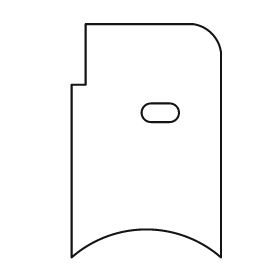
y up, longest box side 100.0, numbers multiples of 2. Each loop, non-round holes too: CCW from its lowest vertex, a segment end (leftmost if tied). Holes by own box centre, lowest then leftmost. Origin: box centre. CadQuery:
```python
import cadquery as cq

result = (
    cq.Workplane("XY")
    .moveTo(-32.0, -50.0)
    .threePointArc((0.0, -38.0), (32.0, -50.0))
    .lineTo(32.0, 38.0)
    .threePointArc((28.0, 46.0), (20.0, 50.0))
    .lineTo(-26.0, 50.0)
    .lineTo(-26.0, 24.0)
    .lineTo(-32.0, 24.0)
    .close()
    .moveTo(2.0, 8.0)
    .lineTo(10.0, 8.0)
    .threePointArc((14.0, 12.0), (10.0, 16.0))
    .lineTo(2.0, 16.0)
    .threePointArc((-2.0, 12.0), (2.0, 8.0))
    .close()
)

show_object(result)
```